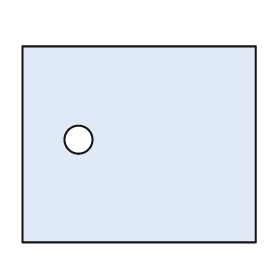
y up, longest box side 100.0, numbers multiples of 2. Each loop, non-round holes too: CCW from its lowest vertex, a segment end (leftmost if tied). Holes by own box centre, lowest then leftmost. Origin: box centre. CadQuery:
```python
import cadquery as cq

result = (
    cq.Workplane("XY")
    .moveTo(-50.0, -42.0)
    .lineTo(50.0, -42.0)
    .lineTo(50.0, 42.0)
    .lineTo(-50.0, 42.0)
    .close()
    .moveTo(-26.0, 2.0)
    .circle(6.0)
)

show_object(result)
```